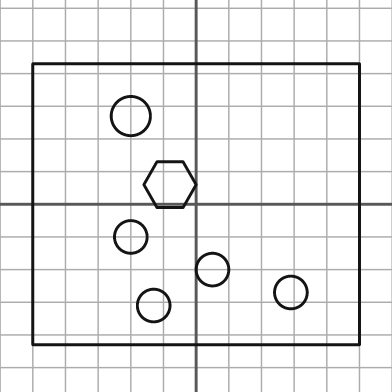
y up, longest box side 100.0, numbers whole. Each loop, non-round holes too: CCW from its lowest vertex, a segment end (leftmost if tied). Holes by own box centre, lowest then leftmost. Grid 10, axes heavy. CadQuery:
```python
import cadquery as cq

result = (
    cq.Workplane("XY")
    .moveTo(-50.0, -43.0)
    .lineTo(50.0, -43.0)
    .lineTo(50.0, 43.0)
    .lineTo(-50.0, 43.0)
    .close()
    .moveTo(-13.0, -31.0)
    .circle(5.0)
    .moveTo(29.0, -27.0)
    .circle(5.0)
    .moveTo(5.0, -20.0)
    .circle(5.0)
    .moveTo(-20.0, -10.0)
    .circle(5.0)
    .moveTo(-12.0, -1.0)
    .lineTo(-4.0, -1.0)
    .lineTo(0.0, 6.0)
    .lineTo(-4.0, 13.0)
    .lineTo(-12.0, 13.0)
    .lineTo(-16.0, 6.0)
    .close()
    .moveTo(-20.0, 27.0)
    .circle(6.0)
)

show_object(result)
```